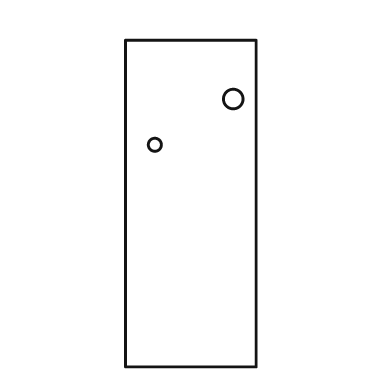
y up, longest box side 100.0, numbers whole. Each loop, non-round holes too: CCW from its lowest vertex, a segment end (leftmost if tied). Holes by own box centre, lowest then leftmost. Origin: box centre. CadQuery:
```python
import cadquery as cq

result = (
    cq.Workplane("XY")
    .moveTo(-20.0, -50.0)
    .lineTo(20.0, -50.0)
    .lineTo(20.0, 50.0)
    .lineTo(-20.0, 50.0)
    .close()
    .moveTo(-11.0, 18.0)
    .circle(2.0)
    .moveTo(13.0, 32.0)
    .circle(3.0)
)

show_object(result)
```